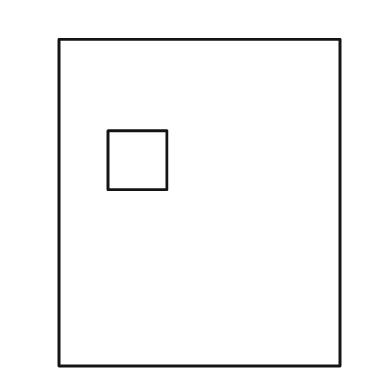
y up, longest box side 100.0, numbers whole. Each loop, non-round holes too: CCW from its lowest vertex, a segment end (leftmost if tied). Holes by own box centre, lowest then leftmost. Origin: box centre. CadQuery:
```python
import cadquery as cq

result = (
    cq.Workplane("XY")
    .moveTo(-43.0, -50.0)
    .lineTo(43.0, -50.0)
    .lineTo(43.0, 50.0)
    .lineTo(-43.0, 50.0)
    .close()
    .moveTo(-28.0, 4.0)
    .lineTo(-10.0, 4.0)
    .lineTo(-10.0, 22.0)
    .lineTo(-28.0, 22.0)
    .close()
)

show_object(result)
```